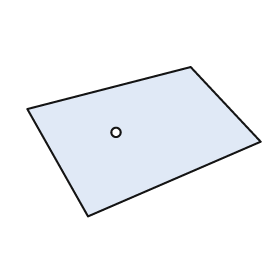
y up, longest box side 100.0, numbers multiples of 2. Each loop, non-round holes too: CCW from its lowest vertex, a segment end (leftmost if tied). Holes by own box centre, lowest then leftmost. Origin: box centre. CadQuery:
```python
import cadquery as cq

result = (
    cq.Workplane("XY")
    .moveTo(-24.0, -32.0)
    .lineTo(50.0, 0.0)
    .lineTo(20.0, 32.0)
    .lineTo(-50.0, 14.0)
    .close()
    .moveTo(-12.0, 4.0)
    .circle(2.0)
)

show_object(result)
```